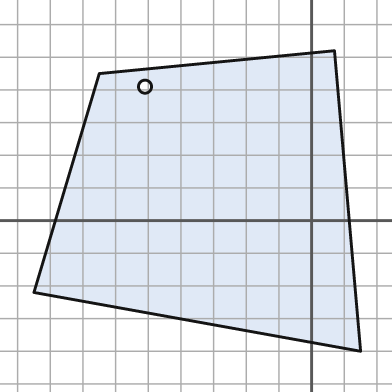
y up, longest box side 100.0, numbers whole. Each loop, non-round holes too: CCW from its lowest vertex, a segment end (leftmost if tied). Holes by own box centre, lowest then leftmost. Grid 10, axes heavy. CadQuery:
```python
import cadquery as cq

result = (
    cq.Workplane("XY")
    .moveTo(15.0, -40.0)
    .lineTo(7.0, 52.0)
    .lineTo(-65.0, 45.0)
    .lineTo(-85.0, -22.0)
    .close()
    .moveTo(-51.0, 41.0)
    .circle(2.0)
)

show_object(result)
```